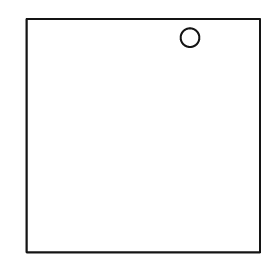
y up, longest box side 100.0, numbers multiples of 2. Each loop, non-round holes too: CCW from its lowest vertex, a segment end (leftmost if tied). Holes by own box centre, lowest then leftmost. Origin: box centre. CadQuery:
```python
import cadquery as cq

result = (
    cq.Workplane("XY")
    .moveTo(-50.0, -50.0)
    .lineTo(50.0, -50.0)
    .lineTo(50.0, 50.0)
    .lineTo(-50.0, 50.0)
    .close()
    .moveTo(20.0, 42.0)
    .circle(4.0)
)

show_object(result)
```